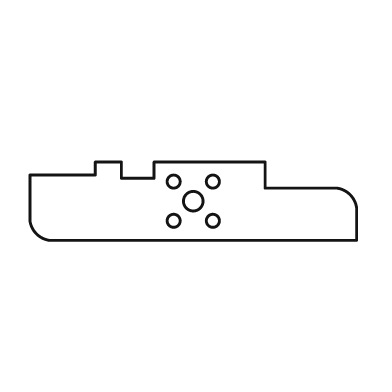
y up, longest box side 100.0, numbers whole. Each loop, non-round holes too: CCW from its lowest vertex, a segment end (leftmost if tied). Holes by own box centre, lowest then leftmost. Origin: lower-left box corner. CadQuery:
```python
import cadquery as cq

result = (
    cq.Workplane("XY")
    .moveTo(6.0, 0.0)
    .lineTo(100.0, 0.0)
    .lineTo(100.0, 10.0)
    .threePointArc((98.0, 14.0), (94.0, 16.0))
    .lineTo(72.0, 16.0)
    .lineTo(72.0, 24.0)
    .lineTo(38.0, 24.0)
    .lineTo(38.0, 19.0)
    .lineTo(28.0, 19.0)
    .lineTo(28.0, 24.0)
    .lineTo(20.0, 24.0)
    .lineTo(20.0, 20.0)
    .lineTo(0.0, 20.0)
    .lineTo(0.0, 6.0)
    .threePointArc((2.0, 2.0), (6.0, 0.0))
    .close()
    .moveTo(44.0, 6.0)
    .circle(2.0)
    .moveTo(56.0, 6.0)
    .circle(2.0)
    .moveTo(50.0, 12.0)
    .circle(3.0)
    .moveTo(44.0, 18.0)
    .circle(2.0)
    .moveTo(56.0, 18.0)
    .circle(2.0)
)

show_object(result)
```